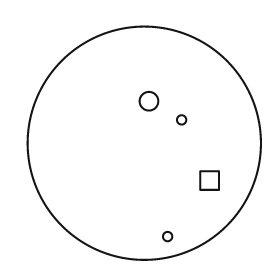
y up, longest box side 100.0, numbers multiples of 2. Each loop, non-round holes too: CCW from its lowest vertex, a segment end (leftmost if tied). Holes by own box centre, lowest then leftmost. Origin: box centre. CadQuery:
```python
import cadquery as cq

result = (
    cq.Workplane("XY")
    .moveTo(0.0, 0.0)
    .circle(50.0)
    .moveTo(10.0, -40.0)
    .circle(2.0)
    .moveTo(24.0, -20.0)
    .lineTo(32.0, -20.0)
    .lineTo(32.0, -12.0)
    .lineTo(24.0, -12.0)
    .close()
    .moveTo(16.0, 10.0)
    .circle(2.0)
    .moveTo(2.0, 18.0)
    .circle(4.0)
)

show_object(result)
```